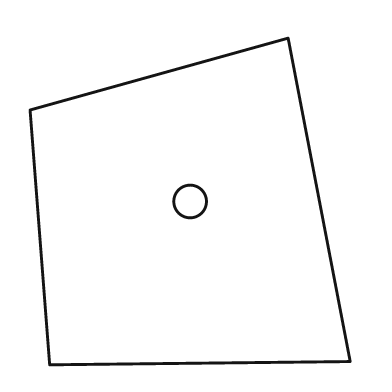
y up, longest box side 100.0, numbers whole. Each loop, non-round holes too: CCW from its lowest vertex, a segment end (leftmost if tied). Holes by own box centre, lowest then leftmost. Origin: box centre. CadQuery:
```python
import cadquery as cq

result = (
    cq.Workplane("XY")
    .moveTo(-43.0, -50.0)
    .lineTo(49.0, -49.0)
    .lineTo(30.0, 50.0)
    .lineTo(-49.0, 28.0)
    .close()
    .moveTo(0.0, 0.0)
    .circle(5.0)
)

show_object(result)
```